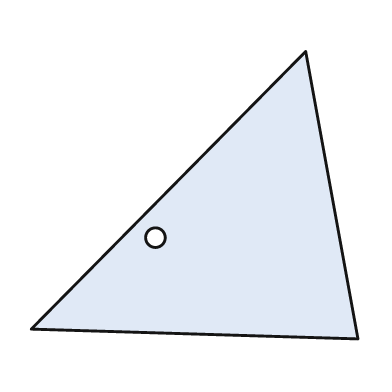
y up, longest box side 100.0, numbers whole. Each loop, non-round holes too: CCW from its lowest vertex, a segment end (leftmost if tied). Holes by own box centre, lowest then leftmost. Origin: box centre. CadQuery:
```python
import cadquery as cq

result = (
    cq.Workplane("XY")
    .moveTo(50.0, -44.0)
    .lineTo(34.0, 44.0)
    .lineTo(-50.0, -41.0)
    .close()
    .moveTo(-12.0, -13.0)
    .circle(3.0)
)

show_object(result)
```